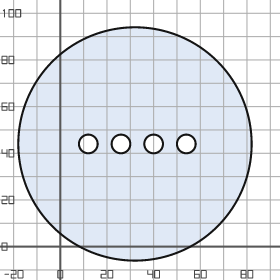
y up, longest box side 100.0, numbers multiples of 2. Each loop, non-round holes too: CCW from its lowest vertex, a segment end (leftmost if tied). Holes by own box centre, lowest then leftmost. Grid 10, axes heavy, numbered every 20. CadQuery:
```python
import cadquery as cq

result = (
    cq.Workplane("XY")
    .moveTo(32.0, 44.0)
    .circle(50.0)
    .moveTo(12.0, 44.0)
    .circle(4.0)
    .moveTo(26.0, 44.0)
    .circle(4.0)
    .moveTo(40.0, 44.0)
    .circle(4.0)
    .moveTo(54.0, 44.0)
    .circle(4.0)
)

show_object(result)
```